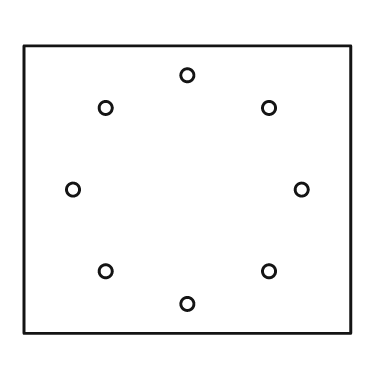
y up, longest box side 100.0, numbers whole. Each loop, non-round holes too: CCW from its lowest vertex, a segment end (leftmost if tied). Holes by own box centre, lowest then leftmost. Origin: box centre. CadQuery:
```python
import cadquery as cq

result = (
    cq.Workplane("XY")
    .moveTo(-50.0, -44.0)
    .lineTo(50.0, -44.0)
    .lineTo(50.0, 44.0)
    .lineTo(-50.0, 44.0)
    .close()
    .moveTo(0.0, -35.0)
    .circle(2.0)
    .moveTo(-25.0, -25.0)
    .circle(2.0)
    .moveTo(25.0, -25.0)
    .circle(2.0)
    .moveTo(-35.0, 0.0)
    .circle(2.0)
    .moveTo(35.0, 0.0)
    .circle(2.0)
    .moveTo(-25.0, 25.0)
    .circle(2.0)
    .moveTo(25.0, 25.0)
    .circle(2.0)
    .moveTo(0.0, 35.0)
    .circle(2.0)
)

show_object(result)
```